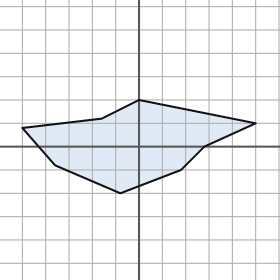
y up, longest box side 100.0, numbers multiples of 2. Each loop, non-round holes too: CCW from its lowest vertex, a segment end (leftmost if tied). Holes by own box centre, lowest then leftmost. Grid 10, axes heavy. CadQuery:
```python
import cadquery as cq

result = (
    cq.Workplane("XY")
    .moveTo(-8.0, -20.0)
    .lineTo(18.0, -10.0)
    .lineTo(28.0, 0.0)
    .lineTo(50.0, 10.0)
    .lineTo(0.0, 20.0)
    .lineTo(-16.0, 12.0)
    .lineTo(-50.0, 8.0)
    .lineTo(-36.0, -8.0)
    .close()
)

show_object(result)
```